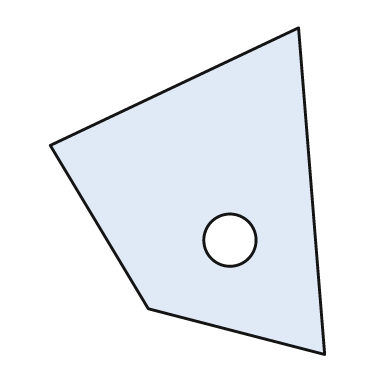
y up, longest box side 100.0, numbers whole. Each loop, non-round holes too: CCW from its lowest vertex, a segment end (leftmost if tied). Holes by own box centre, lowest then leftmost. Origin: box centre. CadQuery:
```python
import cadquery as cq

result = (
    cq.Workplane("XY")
    .moveTo(42.0, -50.0)
    .lineTo(34.0, 50.0)
    .lineTo(-42.0, 14.0)
    .lineTo(-12.0, -36.0)
    .close()
    .moveTo(13.0, -15.0)
    .circle(8.0)
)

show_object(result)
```